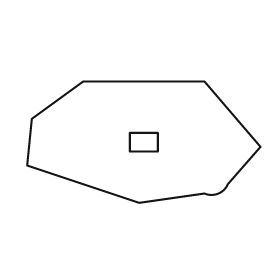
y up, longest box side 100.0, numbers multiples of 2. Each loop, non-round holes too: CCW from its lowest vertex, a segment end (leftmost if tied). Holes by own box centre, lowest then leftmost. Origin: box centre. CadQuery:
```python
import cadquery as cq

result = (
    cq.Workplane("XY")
    .moveTo(-2.0, -26.0)
    .lineTo(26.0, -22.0)
    .threePointArc((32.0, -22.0), (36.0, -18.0))
    .lineTo(50.0, -2.0)
    .lineTo(26.0, 26.0)
    .lineTo(-26.0, 26.0)
    .lineTo(-48.0, 10.0)
    .lineTo(-50.0, -10.0)
    .close()
    .moveTo(-6.0, -4.0)
    .lineTo(6.0, -4.0)
    .lineTo(6.0, 4.0)
    .lineTo(-6.0, 4.0)
    .close()
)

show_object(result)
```